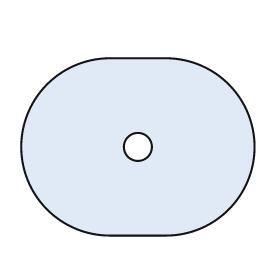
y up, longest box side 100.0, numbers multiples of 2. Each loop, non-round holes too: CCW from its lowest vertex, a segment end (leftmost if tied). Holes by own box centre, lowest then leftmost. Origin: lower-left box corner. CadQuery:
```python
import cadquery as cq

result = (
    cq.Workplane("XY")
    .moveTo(38.0, 0.0)
    .lineTo(62.0, 0.0)
    .threePointArc((100.0, 38.0), (62.0, 76.0))
    .lineTo(38.0, 76.0)
    .threePointArc((0.0, 38.0), (38.0, 0.0))
    .close()
    .moveTo(50.0, 38.0)
    .circle(6.0)
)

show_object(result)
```